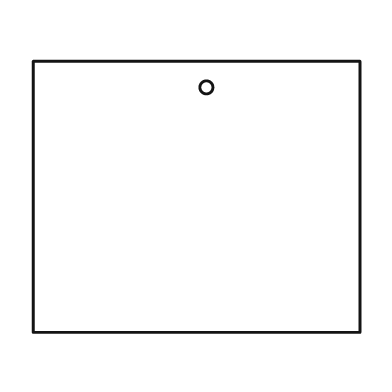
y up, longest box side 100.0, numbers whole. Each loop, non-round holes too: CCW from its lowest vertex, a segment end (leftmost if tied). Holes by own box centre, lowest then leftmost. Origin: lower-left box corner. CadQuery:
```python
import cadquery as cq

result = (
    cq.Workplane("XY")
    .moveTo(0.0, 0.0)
    .lineTo(100.0, 0.0)
    .lineTo(100.0, 83.0)
    .lineTo(0.0, 83.0)
    .close()
    .moveTo(53.0, 75.0)
    .circle(2.0)
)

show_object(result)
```